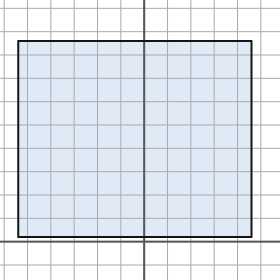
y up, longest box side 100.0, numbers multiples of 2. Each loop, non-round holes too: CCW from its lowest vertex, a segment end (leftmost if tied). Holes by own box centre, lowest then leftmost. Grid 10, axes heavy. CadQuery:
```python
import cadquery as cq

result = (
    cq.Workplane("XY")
    .moveTo(-54.0, 2.0)
    .lineTo(46.0, 2.0)
    .lineTo(46.0, 86.0)
    .lineTo(-54.0, 86.0)
    .close()
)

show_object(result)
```